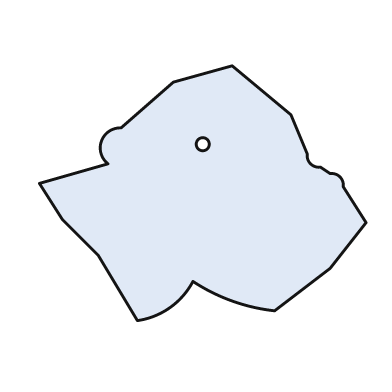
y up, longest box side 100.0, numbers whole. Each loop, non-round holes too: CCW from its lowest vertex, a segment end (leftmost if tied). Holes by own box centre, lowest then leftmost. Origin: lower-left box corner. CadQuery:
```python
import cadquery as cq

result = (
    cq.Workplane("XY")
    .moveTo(30.0, 0.0)
    .threePointArc((40.0, 4.0), (47.0, 12.0))
    .threePointArc((59.0, 6.0), (72.0, 3.0))
    .lineTo(89.0, 16.0)
    .lineTo(100.0, 30.0)
    .lineTo(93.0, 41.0)
    .threePointArc((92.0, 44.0), (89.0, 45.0))
    .lineTo(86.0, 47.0)
    .threePointArc((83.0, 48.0), (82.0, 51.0))
    .lineTo(77.0, 63.0)
    .lineTo(59.0, 78.0)
    .lineTo(41.0, 73.0)
    .lineTo(25.0, 59.0)
    .threePointArc((19.0, 55.0), (21.0, 48.0))
    .lineTo(0.0, 42.0)
    .lineTo(7.0, 31.0)
    .lineTo(18.0, 20.0)
    .close()
    .moveTo(50.0, 54.0)
    .circle(2.0)
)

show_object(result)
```